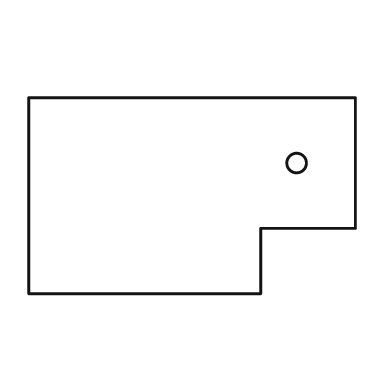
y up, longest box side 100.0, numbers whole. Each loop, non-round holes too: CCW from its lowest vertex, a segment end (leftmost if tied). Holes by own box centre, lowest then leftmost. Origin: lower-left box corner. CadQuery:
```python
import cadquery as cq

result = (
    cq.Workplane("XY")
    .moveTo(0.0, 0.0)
    .lineTo(71.0, 0.0)
    .lineTo(71.0, 20.0)
    .lineTo(100.0, 20.0)
    .lineTo(100.0, 60.0)
    .lineTo(0.0, 60.0)
    .close()
    .moveTo(82.0, 40.0)
    .circle(3.0)
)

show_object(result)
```